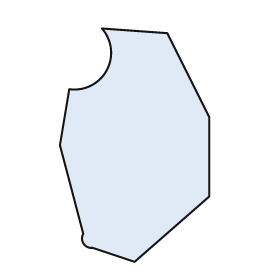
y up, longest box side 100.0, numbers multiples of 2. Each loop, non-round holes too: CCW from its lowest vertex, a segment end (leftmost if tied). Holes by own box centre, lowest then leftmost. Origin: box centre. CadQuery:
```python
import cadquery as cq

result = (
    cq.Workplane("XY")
    .moveTo(0.0, -50.0)
    .lineTo(32.0, -22.0)
    .lineTo(32.0, 12.0)
    .lineTo(14.0, 48.0)
    .lineTo(-14.0, 50.0)
    .threePointArc((-12.0, 32.0), (-28.0, 24.0))
    .lineTo(-32.0, 0.0)
    .lineTo(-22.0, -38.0)
    .threePointArc((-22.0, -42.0), (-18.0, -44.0))
    .close()
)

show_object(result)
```